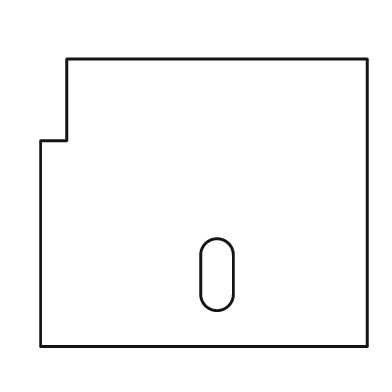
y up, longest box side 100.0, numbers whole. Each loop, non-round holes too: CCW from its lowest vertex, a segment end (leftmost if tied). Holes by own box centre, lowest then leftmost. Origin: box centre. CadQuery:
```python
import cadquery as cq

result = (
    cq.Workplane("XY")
    .moveTo(-50.0, -44.0)
    .lineTo(50.0, -44.0)
    .lineTo(50.0, 44.0)
    .lineTo(-42.0, 44.0)
    .lineTo(-42.0, 19.0)
    .lineTo(-50.0, 19.0)
    .close()
    .moveTo(-1.0, -28.0)
    .threePointArc((4.0, -33.0), (9.0, -28.0))
    .lineTo(9.0, -16.0)
    .threePointArc((4.0, -11.0), (-1.0, -16.0))
    .close()
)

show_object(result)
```